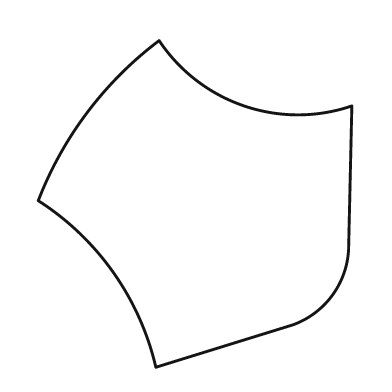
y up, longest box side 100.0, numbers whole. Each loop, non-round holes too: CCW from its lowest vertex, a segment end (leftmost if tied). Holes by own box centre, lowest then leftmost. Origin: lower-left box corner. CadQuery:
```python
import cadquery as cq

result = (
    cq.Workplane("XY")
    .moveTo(36.0, 0.0)
    .lineTo(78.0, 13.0)
    .threePointArc((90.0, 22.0), (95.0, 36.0))
    .lineTo(96.0, 80.0)
    .threePointArc((63.0, 80.0), (37.0, 100.0))
    .threePointArc((15.0, 78.0), (0.0, 51.0))
    .threePointArc((23.0, 29.0), (36.0, 0.0))
    .close()
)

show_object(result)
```